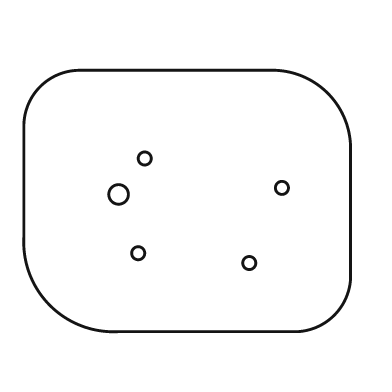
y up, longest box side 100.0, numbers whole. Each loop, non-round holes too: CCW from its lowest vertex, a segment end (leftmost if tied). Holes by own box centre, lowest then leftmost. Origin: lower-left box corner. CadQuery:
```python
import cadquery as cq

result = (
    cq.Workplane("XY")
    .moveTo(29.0, 0.0)
    .lineTo(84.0, 0.0)
    .threePointArc((95.0, 5.0), (100.0, 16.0))
    .lineTo(100.0, 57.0)
    .threePointArc((93.0, 73.0), (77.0, 80.0))
    .lineTo(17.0, 80.0)
    .threePointArc((5.0, 75.0), (0.0, 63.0))
    .lineTo(0.0, 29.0)
    .threePointArc((8.0, 8.0), (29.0, 0.0))
    .close()
    .moveTo(69.0, 21.0)
    .circle(2.0)
    .moveTo(35.0, 24.0)
    .circle(2.0)
    .moveTo(29.0, 42.0)
    .circle(3.0)
    .moveTo(79.0, 44.0)
    .circle(2.0)
    .moveTo(37.0, 53.0)
    .circle(2.0)
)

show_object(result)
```